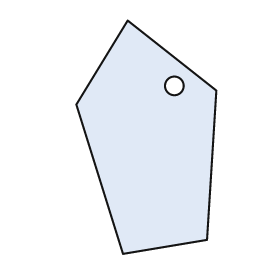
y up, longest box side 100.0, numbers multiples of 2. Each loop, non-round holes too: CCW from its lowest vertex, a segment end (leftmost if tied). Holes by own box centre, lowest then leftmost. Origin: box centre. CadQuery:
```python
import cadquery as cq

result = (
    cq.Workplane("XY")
    .moveTo(-10.0, -50.0)
    .lineTo(26.0, -44.0)
    .lineTo(30.0, 20.0)
    .lineTo(-8.0, 50.0)
    .lineTo(-30.0, 14.0)
    .close()
    .moveTo(12.0, 22.0)
    .circle(4.0)
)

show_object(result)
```